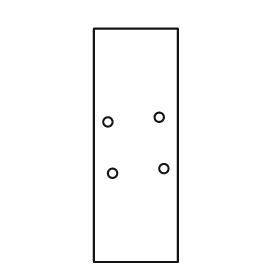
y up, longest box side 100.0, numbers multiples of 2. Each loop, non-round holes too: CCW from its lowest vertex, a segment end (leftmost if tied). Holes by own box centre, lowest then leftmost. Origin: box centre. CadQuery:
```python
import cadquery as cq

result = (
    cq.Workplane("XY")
    .moveTo(-18.0, -50.0)
    .lineTo(18.0, -50.0)
    .lineTo(18.0, 50.0)
    .lineTo(-18.0, 50.0)
    .close()
    .moveTo(-10.0, -12.0)
    .circle(2.0)
    .moveTo(12.0, -10.0)
    .circle(2.0)
    .moveTo(-12.0, 10.0)
    .circle(2.0)
    .moveTo(10.0, 12.0)
    .circle(2.0)
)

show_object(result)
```